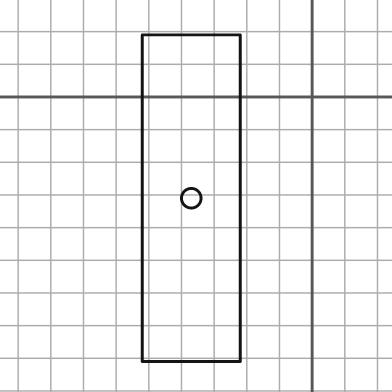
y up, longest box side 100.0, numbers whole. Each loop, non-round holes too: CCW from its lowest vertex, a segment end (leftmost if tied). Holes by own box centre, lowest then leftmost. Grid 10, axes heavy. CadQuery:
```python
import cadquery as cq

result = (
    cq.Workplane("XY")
    .moveTo(-52.0, -81.0)
    .lineTo(-22.0, -81.0)
    .lineTo(-22.0, 19.0)
    .lineTo(-52.0, 19.0)
    .close()
    .moveTo(-37.0, -31.0)
    .circle(3.0)
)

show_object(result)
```